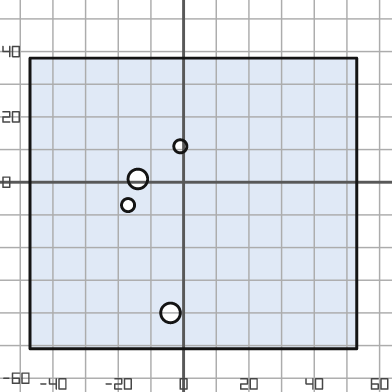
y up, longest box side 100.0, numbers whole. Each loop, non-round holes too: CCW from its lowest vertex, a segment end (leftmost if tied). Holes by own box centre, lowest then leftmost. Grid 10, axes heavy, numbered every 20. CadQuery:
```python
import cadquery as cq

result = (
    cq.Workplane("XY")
    .moveTo(-47.0, -51.0)
    .lineTo(53.0, -51.0)
    .lineTo(53.0, 38.0)
    .lineTo(-47.0, 38.0)
    .close()
    .moveTo(-4.0, -40.0)
    .circle(3.0)
    .moveTo(-17.0, -7.0)
    .circle(2.0)
    .moveTo(-14.0, 1.0)
    .circle(3.0)
    .moveTo(-1.0, 11.0)
    .circle(2.0)
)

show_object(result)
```